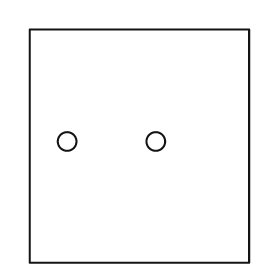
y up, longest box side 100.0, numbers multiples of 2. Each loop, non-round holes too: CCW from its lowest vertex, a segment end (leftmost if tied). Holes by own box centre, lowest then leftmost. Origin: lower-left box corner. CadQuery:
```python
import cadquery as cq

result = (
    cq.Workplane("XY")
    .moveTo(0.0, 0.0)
    .lineTo(94.0, 0.0)
    .lineTo(94.0, 100.0)
    .lineTo(0.0, 100.0)
    .close()
    .moveTo(16.0, 52.0)
    .circle(4.0)
    .moveTo(54.0, 52.0)
    .circle(4.0)
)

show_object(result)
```